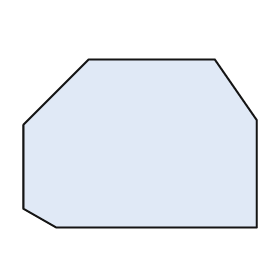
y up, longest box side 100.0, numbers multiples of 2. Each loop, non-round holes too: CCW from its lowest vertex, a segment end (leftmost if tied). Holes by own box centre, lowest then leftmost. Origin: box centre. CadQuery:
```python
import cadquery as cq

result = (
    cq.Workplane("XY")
    .moveTo(-36.0, -36.0)
    .lineTo(50.0, -36.0)
    .lineTo(50.0, 10.0)
    .lineTo(32.0, 36.0)
    .lineTo(-22.0, 36.0)
    .lineTo(-50.0, 8.0)
    .lineTo(-50.0, -28.0)
    .close()
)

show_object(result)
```